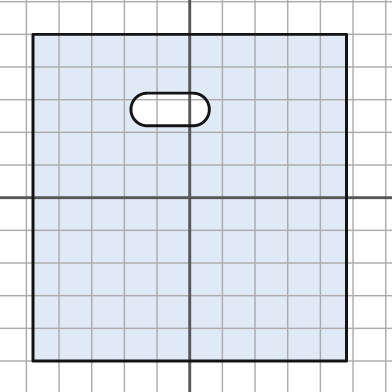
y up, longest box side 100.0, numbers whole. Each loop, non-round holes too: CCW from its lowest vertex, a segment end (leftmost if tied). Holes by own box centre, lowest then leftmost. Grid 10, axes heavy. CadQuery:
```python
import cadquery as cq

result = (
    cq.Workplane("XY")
    .moveTo(-48.0, -50.0)
    .lineTo(48.0, -50.0)
    .lineTo(48.0, 50.0)
    .lineTo(-48.0, 50.0)
    .close()
    .moveTo(-13.0, 22.0)
    .lineTo(1.0, 22.0)
    .threePointArc((6.0, 27.0), (1.0, 32.0))
    .lineTo(-13.0, 32.0)
    .threePointArc((-18.0, 27.0), (-13.0, 22.0))
    .close()
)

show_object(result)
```